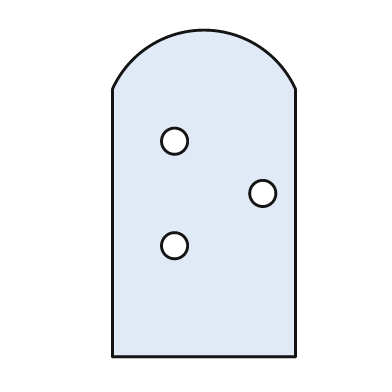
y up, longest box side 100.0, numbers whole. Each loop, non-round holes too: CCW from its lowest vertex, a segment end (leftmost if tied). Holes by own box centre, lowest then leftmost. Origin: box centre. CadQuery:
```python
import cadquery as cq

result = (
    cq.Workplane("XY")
    .moveTo(-28.0, -50.0)
    .lineTo(28.0, -50.0)
    .lineTo(28.0, 32.0)
    .threePointArc((0.0, 50.0), (-28.0, 32.0))
    .close()
    .moveTo(-9.0, -16.0)
    .circle(4.0)
    .moveTo(18.0, 0.0)
    .circle(4.0)
    .moveTo(-9.0, 16.0)
    .circle(4.0)
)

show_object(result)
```